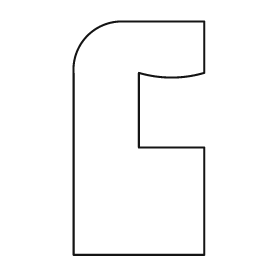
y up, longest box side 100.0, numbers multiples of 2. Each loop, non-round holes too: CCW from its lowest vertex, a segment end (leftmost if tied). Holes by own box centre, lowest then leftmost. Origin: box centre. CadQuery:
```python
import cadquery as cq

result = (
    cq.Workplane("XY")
    .moveTo(-28.0, -50.0)
    .lineTo(28.0, -50.0)
    .lineTo(28.0, -4.0)
    .lineTo(0.0, -4.0)
    .lineTo(0.0, 28.0)
    .threePointArc((14.0, 26.0), (28.0, 28.0))
    .lineTo(28.0, 50.0)
    .lineTo(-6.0, 50.0)
    .threePointArc((-22.0, 44.0), (-28.0, 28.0))
    .close()
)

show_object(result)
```